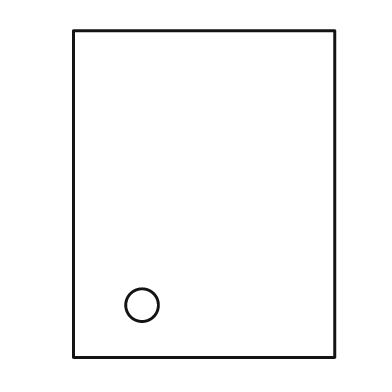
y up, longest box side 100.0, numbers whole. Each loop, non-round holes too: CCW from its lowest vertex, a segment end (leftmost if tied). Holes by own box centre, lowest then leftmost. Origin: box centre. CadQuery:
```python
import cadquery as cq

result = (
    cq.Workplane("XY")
    .moveTo(-40.0, -50.0)
    .lineTo(40.0, -50.0)
    .lineTo(40.0, 50.0)
    .lineTo(-40.0, 50.0)
    .close()
    .moveTo(-19.0, -34.0)
    .circle(5.0)
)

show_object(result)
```